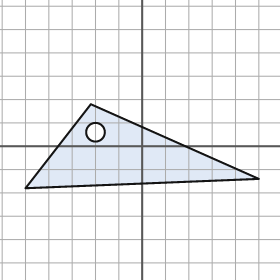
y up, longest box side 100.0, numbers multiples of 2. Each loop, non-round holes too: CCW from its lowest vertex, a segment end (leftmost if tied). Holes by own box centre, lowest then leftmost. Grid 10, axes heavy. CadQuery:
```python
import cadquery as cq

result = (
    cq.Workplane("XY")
    .moveTo(-50.0, -18.0)
    .lineTo(50.0, -14.0)
    .lineTo(-22.0, 18.0)
    .close()
    .moveTo(-20.0, 6.0)
    .circle(4.0)
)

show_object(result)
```